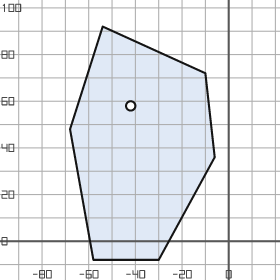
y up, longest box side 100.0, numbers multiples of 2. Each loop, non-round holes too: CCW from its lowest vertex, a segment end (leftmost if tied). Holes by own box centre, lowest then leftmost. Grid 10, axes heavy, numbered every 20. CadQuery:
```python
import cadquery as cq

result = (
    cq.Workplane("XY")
    .moveTo(-58.0, -8.0)
    .lineTo(-30.0, -8.0)
    .lineTo(-6.0, 36.0)
    .lineTo(-10.0, 72.0)
    .lineTo(-54.0, 92.0)
    .lineTo(-68.0, 48.0)
    .close()
    .moveTo(-42.0, 58.0)
    .circle(2.0)
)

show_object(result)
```